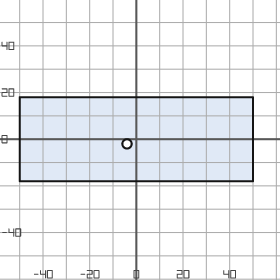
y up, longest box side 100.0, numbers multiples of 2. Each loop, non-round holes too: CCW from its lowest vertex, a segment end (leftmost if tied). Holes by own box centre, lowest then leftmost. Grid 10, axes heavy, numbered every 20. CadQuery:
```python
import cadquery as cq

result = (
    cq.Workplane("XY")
    .moveTo(-50.0, -18.0)
    .lineTo(50.0, -18.0)
    .lineTo(50.0, 18.0)
    .lineTo(-50.0, 18.0)
    .close()
    .moveTo(-4.0, -2.0)
    .circle(2.0)
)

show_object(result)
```